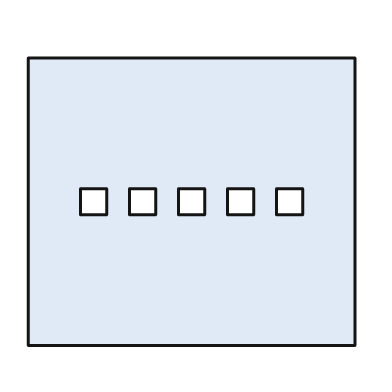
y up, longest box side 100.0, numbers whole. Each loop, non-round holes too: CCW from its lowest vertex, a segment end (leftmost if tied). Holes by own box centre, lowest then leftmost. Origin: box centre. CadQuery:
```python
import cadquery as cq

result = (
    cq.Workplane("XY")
    .moveTo(-50.0, -44.0)
    .lineTo(50.0, -44.0)
    .lineTo(50.0, 44.0)
    .lineTo(-50.0, 44.0)
    .close()
    .moveTo(-34.0, -4.0)
    .lineTo(-26.0, -4.0)
    .lineTo(-26.0, 4.0)
    .lineTo(-34.0, 4.0)
    .close()
    .moveTo(-19.0, -4.0)
    .lineTo(-11.0, -4.0)
    .lineTo(-11.0, 4.0)
    .lineTo(-19.0, 4.0)
    .close()
    .moveTo(-4.0, -4.0)
    .lineTo(4.0, -4.0)
    .lineTo(4.0, 4.0)
    .lineTo(-4.0, 4.0)
    .close()
    .moveTo(11.0, -4.0)
    .lineTo(19.0, -4.0)
    .lineTo(19.0, 4.0)
    .lineTo(11.0, 4.0)
    .close()
    .moveTo(26.0, -4.0)
    .lineTo(34.0, -4.0)
    .lineTo(34.0, 4.0)
    .lineTo(26.0, 4.0)
    .close()
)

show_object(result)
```